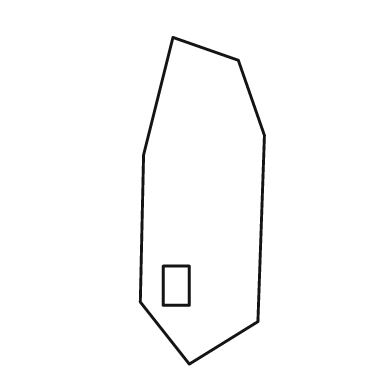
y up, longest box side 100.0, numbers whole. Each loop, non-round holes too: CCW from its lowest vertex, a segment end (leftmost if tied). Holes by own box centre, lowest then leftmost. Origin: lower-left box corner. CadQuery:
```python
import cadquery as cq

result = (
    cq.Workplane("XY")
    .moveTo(15.0, 0.0)
    .lineTo(36.0, 13.0)
    .lineTo(38.0, 70.0)
    .lineTo(30.0, 93.0)
    .lineTo(10.0, 100.0)
    .lineTo(1.0, 64.0)
    .lineTo(0.0, 19.0)
    .close()
    .moveTo(7.0, 18.0)
    .lineTo(15.0, 18.0)
    .lineTo(15.0, 30.0)
    .lineTo(7.0, 30.0)
    .close()
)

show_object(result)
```